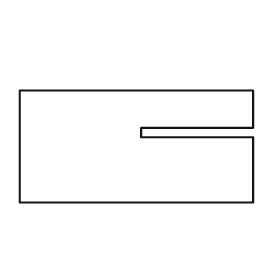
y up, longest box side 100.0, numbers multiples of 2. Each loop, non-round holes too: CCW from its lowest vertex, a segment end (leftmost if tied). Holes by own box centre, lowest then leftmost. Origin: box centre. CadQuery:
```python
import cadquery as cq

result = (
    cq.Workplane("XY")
    .moveTo(-50.0, -24.0)
    .lineTo(50.0, -24.0)
    .lineTo(50.0, 4.0)
    .lineTo(2.0, 4.0)
    .lineTo(2.0, 8.0)
    .lineTo(50.0, 8.0)
    .lineTo(50.0, 24.0)
    .lineTo(-50.0, 24.0)
    .close()
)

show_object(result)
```